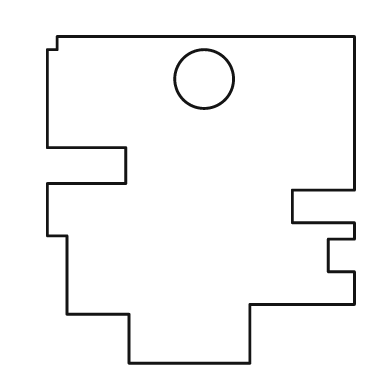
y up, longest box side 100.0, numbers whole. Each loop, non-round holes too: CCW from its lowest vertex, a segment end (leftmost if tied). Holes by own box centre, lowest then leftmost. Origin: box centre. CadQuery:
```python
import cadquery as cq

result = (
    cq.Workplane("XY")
    .moveTo(-22.0, -50.0)
    .lineTo(15.0, -50.0)
    .lineTo(15.0, -32.0)
    .lineTo(47.0, -32.0)
    .lineTo(47.0, -22.0)
    .lineTo(39.0, -22.0)
    .lineTo(39.0, -12.0)
    .lineTo(47.0, -12.0)
    .lineTo(47.0, -7.0)
    .lineTo(28.0, -7.0)
    .lineTo(28.0, 3.0)
    .lineTo(47.0, 3.0)
    .lineTo(47.0, 50.0)
    .lineTo(-44.0, 50.0)
    .lineTo(-44.0, 46.0)
    .lineTo(-47.0, 46.0)
    .lineTo(-47.0, 16.0)
    .lineTo(-23.0, 16.0)
    .lineTo(-23.0, 5.0)
    .lineTo(-47.0, 5.0)
    .lineTo(-47.0, -11.0)
    .lineTo(-41.0, -11.0)
    .lineTo(-41.0, -35.0)
    .lineTo(-22.0, -35.0)
    .close()
    .moveTo(1.0, 37.0)
    .circle(9.0)
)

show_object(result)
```